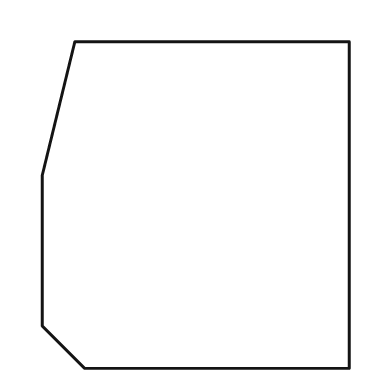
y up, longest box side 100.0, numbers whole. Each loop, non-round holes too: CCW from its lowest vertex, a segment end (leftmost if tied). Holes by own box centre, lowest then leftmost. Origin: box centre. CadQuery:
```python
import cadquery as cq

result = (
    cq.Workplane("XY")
    .moveTo(-34.0, -50.0)
    .lineTo(47.0, -50.0)
    .lineTo(47.0, 50.0)
    .lineTo(-37.0, 50.0)
    .lineTo(-47.0, 9.0)
    .lineTo(-47.0, -37.0)
    .close()
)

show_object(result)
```